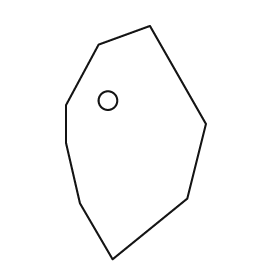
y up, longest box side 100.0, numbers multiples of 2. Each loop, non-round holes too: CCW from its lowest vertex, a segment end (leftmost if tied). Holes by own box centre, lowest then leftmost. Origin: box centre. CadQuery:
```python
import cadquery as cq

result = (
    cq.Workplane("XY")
    .moveTo(-10.0, -50.0)
    .lineTo(22.0, -24.0)
    .lineTo(30.0, 8.0)
    .lineTo(6.0, 50.0)
    .lineTo(-16.0, 42.0)
    .lineTo(-30.0, 16.0)
    .lineTo(-30.0, 0.0)
    .lineTo(-24.0, -26.0)
    .close()
    .moveTo(-12.0, 18.0)
    .circle(4.0)
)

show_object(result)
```